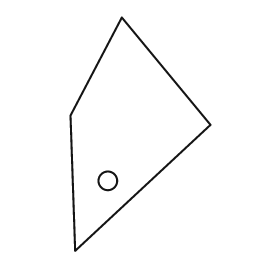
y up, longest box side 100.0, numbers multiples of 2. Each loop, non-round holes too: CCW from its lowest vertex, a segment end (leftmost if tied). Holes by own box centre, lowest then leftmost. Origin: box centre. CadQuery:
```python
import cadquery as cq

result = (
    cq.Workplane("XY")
    .moveTo(-28.0, -50.0)
    .lineTo(30.0, 4.0)
    .lineTo(-8.0, 50.0)
    .lineTo(-30.0, 8.0)
    .close()
    .moveTo(-14.0, -20.0)
    .circle(4.0)
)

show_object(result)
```